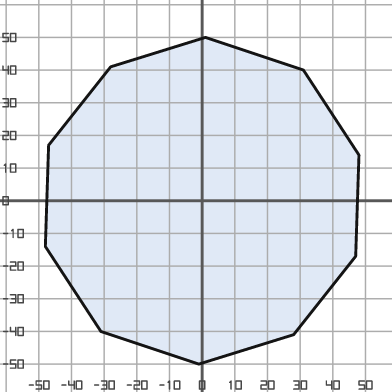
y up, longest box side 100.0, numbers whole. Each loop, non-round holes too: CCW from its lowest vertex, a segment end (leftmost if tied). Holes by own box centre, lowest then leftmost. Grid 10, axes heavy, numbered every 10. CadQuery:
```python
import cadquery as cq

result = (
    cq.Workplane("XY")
    .moveTo(-1.0, -50.0)
    .lineTo(28.0, -41.0)
    .lineTo(47.0, -17.0)
    .lineTo(48.0, 14.0)
    .lineTo(31.0, 40.0)
    .lineTo(1.0, 50.0)
    .lineTo(-28.0, 41.0)
    .lineTo(-47.0, 17.0)
    .lineTo(-48.0, -14.0)
    .lineTo(-31.0, -40.0)
    .close()
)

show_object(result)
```